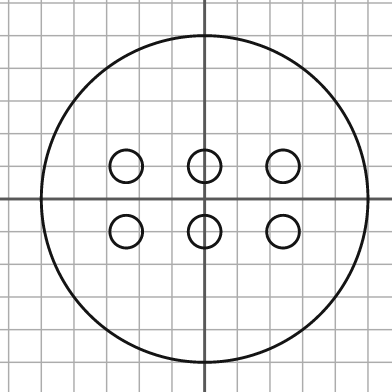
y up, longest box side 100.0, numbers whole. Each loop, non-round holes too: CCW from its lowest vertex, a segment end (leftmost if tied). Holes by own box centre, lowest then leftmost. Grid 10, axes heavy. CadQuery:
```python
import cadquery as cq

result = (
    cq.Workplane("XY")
    .moveTo(0.0, 0.0)
    .circle(50.0)
    .moveTo(-24.0, -10.0)
    .circle(5.0)
    .moveTo(0.0, -10.0)
    .circle(5.0)
    .moveTo(24.0, -10.0)
    .circle(5.0)
    .moveTo(-24.0, 10.0)
    .circle(5.0)
    .moveTo(0.0, 10.0)
    .circle(5.0)
    .moveTo(24.0, 10.0)
    .circle(5.0)
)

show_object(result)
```